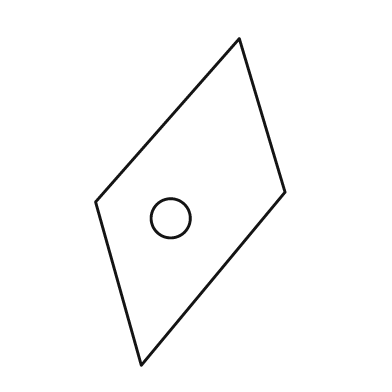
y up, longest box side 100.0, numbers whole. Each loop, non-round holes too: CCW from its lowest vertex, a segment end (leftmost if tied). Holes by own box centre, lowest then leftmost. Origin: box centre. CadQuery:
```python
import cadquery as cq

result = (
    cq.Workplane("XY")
    .moveTo(-15.0, -50.0)
    .lineTo(29.0, 3.0)
    .lineTo(15.0, 50.0)
    .lineTo(-29.0, 0.0)
    .close()
    .moveTo(-6.0, -5.0)
    .circle(6.0)
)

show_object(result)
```